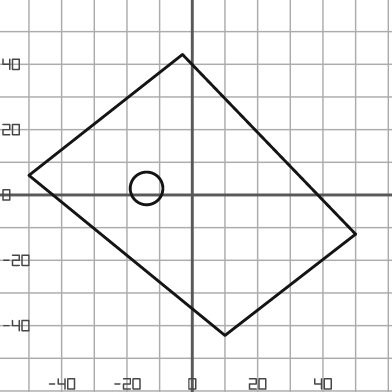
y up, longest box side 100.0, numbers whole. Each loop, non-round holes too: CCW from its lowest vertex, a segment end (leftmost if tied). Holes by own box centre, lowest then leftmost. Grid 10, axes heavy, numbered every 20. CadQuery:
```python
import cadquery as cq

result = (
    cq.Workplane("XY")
    .moveTo(10.0, -43.0)
    .lineTo(50.0, -12.0)
    .lineTo(-3.0, 43.0)
    .lineTo(-50.0, 6.0)
    .close()
    .moveTo(-14.0, 2.0)
    .circle(5.0)
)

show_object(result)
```